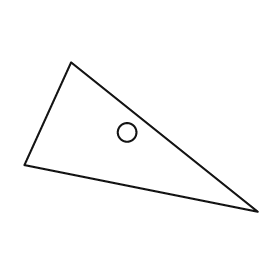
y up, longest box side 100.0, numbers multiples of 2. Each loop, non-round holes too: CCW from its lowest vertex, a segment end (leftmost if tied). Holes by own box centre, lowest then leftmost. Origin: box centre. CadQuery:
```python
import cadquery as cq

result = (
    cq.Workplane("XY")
    .moveTo(50.0, -32.0)
    .lineTo(-30.0, 32.0)
    .lineTo(-50.0, -12.0)
    .close()
    .moveTo(-6.0, 2.0)
    .circle(4.0)
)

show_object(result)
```